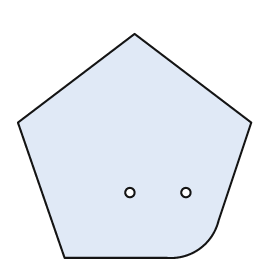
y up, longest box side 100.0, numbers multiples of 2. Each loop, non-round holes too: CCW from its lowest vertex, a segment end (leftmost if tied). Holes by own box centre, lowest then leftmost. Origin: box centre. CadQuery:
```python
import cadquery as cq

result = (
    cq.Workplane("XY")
    .moveTo(-30.0, -48.0)
    .lineTo(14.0, -48.0)
    .threePointArc((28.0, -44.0), (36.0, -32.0))
    .lineTo(50.0, 10.0)
    .lineTo(0.0, 48.0)
    .lineTo(-50.0, 10.0)
    .close()
    .moveTo(-2.0, -20.0)
    .circle(2.0)
    .moveTo(22.0, -20.0)
    .circle(2.0)
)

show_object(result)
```